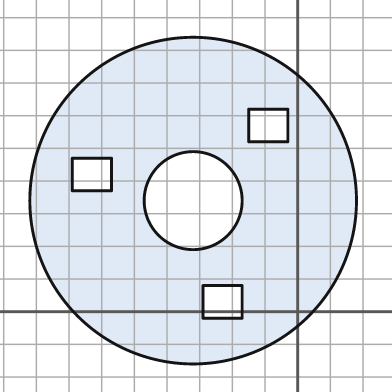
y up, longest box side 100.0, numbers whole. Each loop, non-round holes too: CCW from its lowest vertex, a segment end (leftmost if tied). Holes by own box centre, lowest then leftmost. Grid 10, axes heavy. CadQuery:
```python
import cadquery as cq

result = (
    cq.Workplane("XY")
    .moveTo(-32.0, 34.0)
    .circle(50.0)
    .moveTo(-29.0, -2.0)
    .lineTo(-17.0, -2.0)
    .lineTo(-17.0, 8.0)
    .lineTo(-29.0, 8.0)
    .close()
    .moveTo(-32.0, 34.0)
    .circle(15.0)
    .moveTo(-69.0, 37.0)
    .lineTo(-57.0, 37.0)
    .lineTo(-57.0, 47.0)
    .lineTo(-69.0, 47.0)
    .close()
    .moveTo(-15.0, 52.0)
    .lineTo(-3.0, 52.0)
    .lineTo(-3.0, 62.0)
    .lineTo(-15.0, 62.0)
    .close()
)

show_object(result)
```